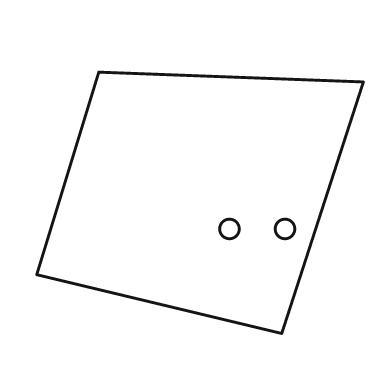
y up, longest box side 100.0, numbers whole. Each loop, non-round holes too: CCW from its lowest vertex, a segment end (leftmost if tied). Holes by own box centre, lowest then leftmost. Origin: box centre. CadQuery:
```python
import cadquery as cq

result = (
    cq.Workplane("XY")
    .moveTo(25.0, -40.0)
    .lineTo(50.0, 37.0)
    .lineTo(-31.0, 40.0)
    .lineTo(-50.0, -22.0)
    .close()
    .moveTo(9.0, -8.0)
    .circle(3.0)
    .moveTo(26.0, -8.0)
    .circle(3.0)
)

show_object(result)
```